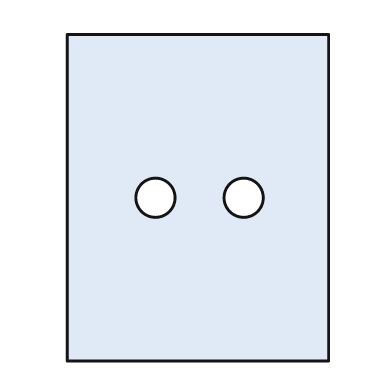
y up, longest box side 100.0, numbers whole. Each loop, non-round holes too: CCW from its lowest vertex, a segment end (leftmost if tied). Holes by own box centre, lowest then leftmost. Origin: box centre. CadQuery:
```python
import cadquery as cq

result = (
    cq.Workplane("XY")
    .moveTo(-40.0, -50.0)
    .lineTo(40.0, -50.0)
    .lineTo(40.0, 50.0)
    .lineTo(-40.0, 50.0)
    .close()
    .moveTo(-13.0, 0.0)
    .circle(6.0)
    .moveTo(14.0, 0.0)
    .circle(6.0)
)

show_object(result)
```